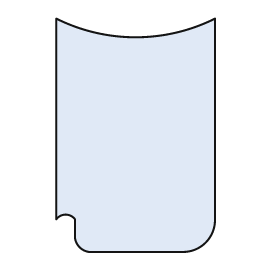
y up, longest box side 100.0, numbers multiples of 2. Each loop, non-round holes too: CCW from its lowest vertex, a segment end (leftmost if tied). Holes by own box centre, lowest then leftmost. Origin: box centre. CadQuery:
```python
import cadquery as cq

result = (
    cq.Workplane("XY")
    .moveTo(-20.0, -50.0)
    .lineTo(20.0, -50.0)
    .threePointArc((30.0, -46.0), (34.0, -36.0))
    .lineTo(34.0, 50.0)
    .threePointArc((0.0, 42.0), (-34.0, 50.0))
    .lineTo(-34.0, -36.0)
    .threePointArc((-30.0, -34.0), (-26.0, -36.0))
    .lineTo(-26.0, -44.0)
    .threePointArc((-24.0, -48.0), (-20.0, -50.0))
    .close()
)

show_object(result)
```